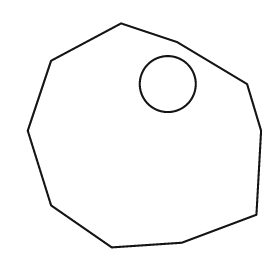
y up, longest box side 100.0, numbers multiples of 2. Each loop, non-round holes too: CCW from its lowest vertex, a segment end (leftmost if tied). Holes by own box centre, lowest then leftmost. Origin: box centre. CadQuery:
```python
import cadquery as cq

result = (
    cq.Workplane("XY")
    .moveTo(-14.0, -48.0)
    .lineTo(16.0, -46.0)
    .lineTo(48.0, -34.0)
    .lineTo(50.0, 2.0)
    .lineTo(44.0, 22.0)
    .lineTo(14.0, 40.0)
    .lineTo(-10.0, 48.0)
    .lineTo(-40.0, 32.0)
    .lineTo(-50.0, 2.0)
    .lineTo(-40.0, -30.0)
    .close()
    .moveTo(10.0, 22.0)
    .circle(12.0)
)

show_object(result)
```